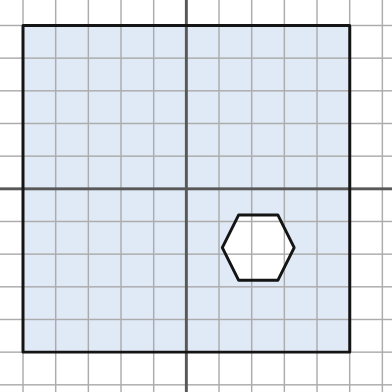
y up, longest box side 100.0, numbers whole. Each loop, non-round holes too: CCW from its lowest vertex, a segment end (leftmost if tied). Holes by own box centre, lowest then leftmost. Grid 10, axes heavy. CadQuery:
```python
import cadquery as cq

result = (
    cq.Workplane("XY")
    .moveTo(-50.0, -50.0)
    .lineTo(50.0, -50.0)
    .lineTo(50.0, 50.0)
    .lineTo(-50.0, 50.0)
    .close()
    .moveTo(16.0, -28.0)
    .lineTo(28.0, -28.0)
    .lineTo(33.0, -18.0)
    .lineTo(28.0, -8.0)
    .lineTo(16.0, -8.0)
    .lineTo(11.0, -18.0)
    .close()
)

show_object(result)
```